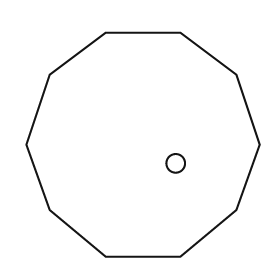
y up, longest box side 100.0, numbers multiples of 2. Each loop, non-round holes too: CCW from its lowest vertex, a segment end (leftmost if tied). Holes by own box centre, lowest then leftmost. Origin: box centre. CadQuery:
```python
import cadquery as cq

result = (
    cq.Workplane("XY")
    .moveTo(-16.0, -48.0)
    .lineTo(16.0, -48.0)
    .lineTo(40.0, -28.0)
    .lineTo(50.0, 0.0)
    .lineTo(40.0, 30.0)
    .lineTo(16.0, 48.0)
    .lineTo(-16.0, 48.0)
    .lineTo(-40.0, 30.0)
    .lineTo(-50.0, 0.0)
    .lineTo(-40.0, -28.0)
    .close()
    .moveTo(14.0, -8.0)
    .circle(4.0)
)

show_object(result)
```